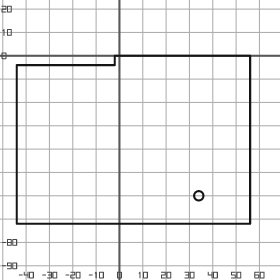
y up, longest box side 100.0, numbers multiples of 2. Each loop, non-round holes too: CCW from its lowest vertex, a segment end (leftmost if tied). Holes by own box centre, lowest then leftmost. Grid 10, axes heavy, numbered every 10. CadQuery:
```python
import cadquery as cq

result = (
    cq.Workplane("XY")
    .moveTo(-44.0, -72.0)
    .lineTo(56.0, -72.0)
    .lineTo(56.0, 0.0)
    .lineTo(-2.0, 0.0)
    .lineTo(-2.0, -4.0)
    .lineTo(-44.0, -4.0)
    .close()
    .moveTo(34.0, -60.0)
    .circle(2.0)
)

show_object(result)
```